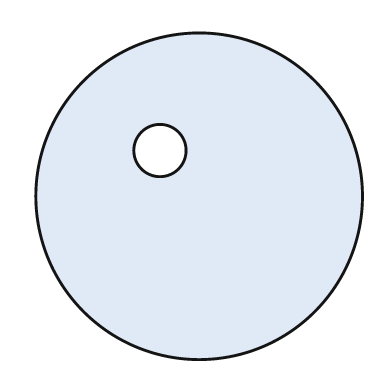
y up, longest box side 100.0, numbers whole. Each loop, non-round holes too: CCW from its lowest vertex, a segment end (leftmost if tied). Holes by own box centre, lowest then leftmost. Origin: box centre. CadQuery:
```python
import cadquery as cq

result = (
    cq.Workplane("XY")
    .moveTo(0.0, 0.0)
    .circle(50.0)
    .moveTo(-12.0, 14.0)
    .circle(8.0)
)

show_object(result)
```